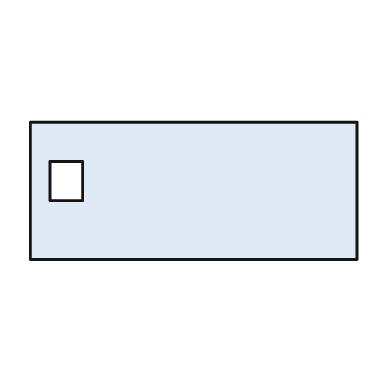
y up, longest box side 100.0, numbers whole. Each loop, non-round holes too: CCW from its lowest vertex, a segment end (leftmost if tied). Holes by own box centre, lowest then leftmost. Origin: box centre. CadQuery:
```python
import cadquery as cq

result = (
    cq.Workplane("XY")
    .moveTo(-50.0, -21.0)
    .lineTo(50.0, -21.0)
    .lineTo(50.0, 21.0)
    .lineTo(-50.0, 21.0)
    .close()
    .moveTo(-44.0, -3.0)
    .lineTo(-34.0, -3.0)
    .lineTo(-34.0, 9.0)
    .lineTo(-44.0, 9.0)
    .close()
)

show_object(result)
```